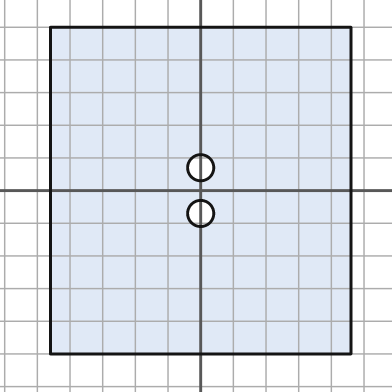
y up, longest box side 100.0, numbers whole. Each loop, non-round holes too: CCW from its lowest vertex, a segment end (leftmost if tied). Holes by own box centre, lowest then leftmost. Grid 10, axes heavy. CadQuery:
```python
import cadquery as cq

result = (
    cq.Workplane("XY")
    .moveTo(-46.0, -50.0)
    .lineTo(46.0, -50.0)
    .lineTo(46.0, 50.0)
    .lineTo(-46.0, 50.0)
    .close()
    .moveTo(0.0, -7.0)
    .circle(4.0)
    .moveTo(0.0, 7.0)
    .circle(4.0)
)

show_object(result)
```